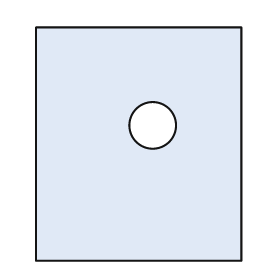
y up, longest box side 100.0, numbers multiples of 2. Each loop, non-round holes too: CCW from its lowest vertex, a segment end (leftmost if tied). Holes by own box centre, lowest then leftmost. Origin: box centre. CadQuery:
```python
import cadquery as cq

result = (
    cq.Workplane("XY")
    .moveTo(-44.0, -50.0)
    .lineTo(44.0, -50.0)
    .lineTo(44.0, 50.0)
    .lineTo(-44.0, 50.0)
    .close()
    .moveTo(6.0, 8.0)
    .circle(10.0)
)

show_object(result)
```